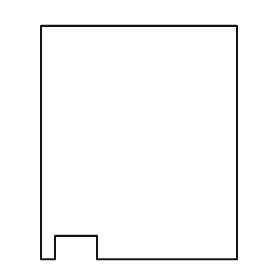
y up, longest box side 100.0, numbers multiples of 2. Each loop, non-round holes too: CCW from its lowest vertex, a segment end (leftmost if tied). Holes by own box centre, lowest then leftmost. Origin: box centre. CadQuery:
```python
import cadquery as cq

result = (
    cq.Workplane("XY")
    .moveTo(-42.0, -50.0)
    .lineTo(-36.0, -50.0)
    .lineTo(-36.0, -40.0)
    .lineTo(-18.0, -40.0)
    .lineTo(-18.0, -50.0)
    .lineTo(42.0, -50.0)
    .lineTo(42.0, 50.0)
    .lineTo(-42.0, 50.0)
    .close()
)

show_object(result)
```